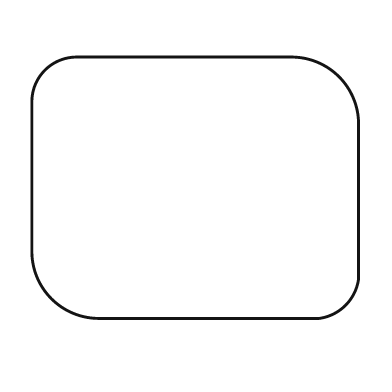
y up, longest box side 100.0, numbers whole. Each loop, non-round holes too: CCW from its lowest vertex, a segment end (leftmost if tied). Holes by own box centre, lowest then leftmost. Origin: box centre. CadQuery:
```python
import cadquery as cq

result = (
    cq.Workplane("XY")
    .moveTo(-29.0, -40.0)
    .lineTo(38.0, -40.0)
    .threePointArc((46.0, -36.0), (50.0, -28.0))
    .lineTo(50.0, 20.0)
    .threePointArc((44.0, 34.0), (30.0, 40.0))
    .lineTo(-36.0, 40.0)
    .threePointArc((-46.0, 36.0), (-50.0, 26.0))
    .lineTo(-50.0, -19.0)
    .threePointArc((-44.0, -34.0), (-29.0, -40.0))
    .close()
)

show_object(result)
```